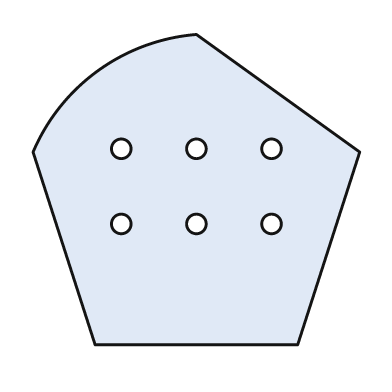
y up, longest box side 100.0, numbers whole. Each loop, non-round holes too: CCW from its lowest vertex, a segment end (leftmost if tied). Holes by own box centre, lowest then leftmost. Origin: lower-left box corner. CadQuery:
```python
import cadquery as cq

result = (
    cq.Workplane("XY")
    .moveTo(19.0, 0.0)
    .lineTo(81.0, 0.0)
    .lineTo(100.0, 59.0)
    .lineTo(50.0, 95.0)
    .threePointArc((20.0, 84.0), (0.0, 59.0))
    .close()
    .moveTo(27.0, 37.0)
    .circle(3.0)
    .moveTo(50.0, 37.0)
    .circle(3.0)
    .moveTo(73.0, 37.0)
    .circle(3.0)
    .moveTo(27.0, 60.0)
    .circle(3.0)
    .moveTo(50.0, 60.0)
    .circle(3.0)
    .moveTo(73.0, 60.0)
    .circle(3.0)
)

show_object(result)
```